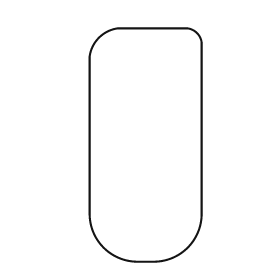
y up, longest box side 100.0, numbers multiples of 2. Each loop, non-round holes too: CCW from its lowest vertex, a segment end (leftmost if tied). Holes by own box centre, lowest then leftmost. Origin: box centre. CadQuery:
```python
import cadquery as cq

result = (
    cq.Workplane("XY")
    .moveTo(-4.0, -50.0)
    .lineTo(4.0, -50.0)
    .threePointArc((18.0, -44.0), (24.0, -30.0))
    .lineTo(24.0, 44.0)
    .threePointArc((22.0, 48.0), (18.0, 50.0))
    .lineTo(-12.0, 50.0)
    .threePointArc((-20.0, 46.0), (-24.0, 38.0))
    .lineTo(-24.0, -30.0)
    .threePointArc((-18.0, -44.0), (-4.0, -50.0))
    .close()
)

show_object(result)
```